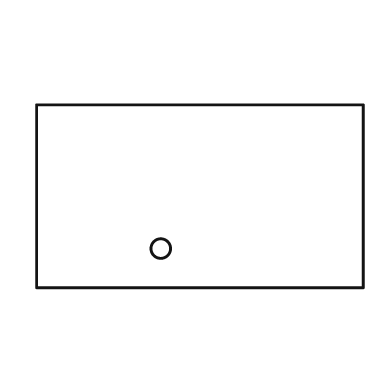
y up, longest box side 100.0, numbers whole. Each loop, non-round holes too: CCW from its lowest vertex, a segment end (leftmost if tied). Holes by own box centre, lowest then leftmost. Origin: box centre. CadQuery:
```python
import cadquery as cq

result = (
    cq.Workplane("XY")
    .moveTo(-50.0, -28.0)
    .lineTo(50.0, -28.0)
    .lineTo(50.0, 28.0)
    .lineTo(-50.0, 28.0)
    .close()
    .moveTo(-12.0, -16.0)
    .circle(3.0)
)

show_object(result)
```